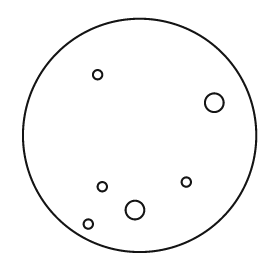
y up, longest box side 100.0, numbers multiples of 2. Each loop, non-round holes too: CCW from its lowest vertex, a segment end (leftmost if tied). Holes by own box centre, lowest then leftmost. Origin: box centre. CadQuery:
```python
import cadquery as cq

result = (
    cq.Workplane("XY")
    .moveTo(0.0, 0.0)
    .circle(50.0)
    .moveTo(-22.0, -38.0)
    .circle(2.0)
    .moveTo(-2.0, -32.0)
    .circle(4.0)
    .moveTo(-16.0, -22.0)
    .circle(2.0)
    .moveTo(20.0, -20.0)
    .circle(2.0)
    .moveTo(32.0, 14.0)
    .circle(4.0)
    .moveTo(-18.0, 26.0)
    .circle(2.0)
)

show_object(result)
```